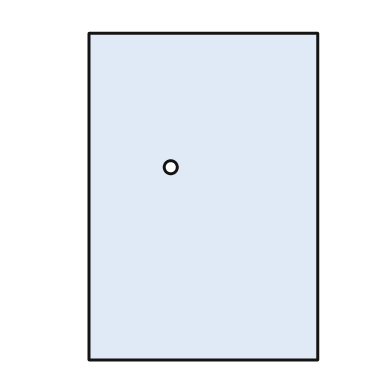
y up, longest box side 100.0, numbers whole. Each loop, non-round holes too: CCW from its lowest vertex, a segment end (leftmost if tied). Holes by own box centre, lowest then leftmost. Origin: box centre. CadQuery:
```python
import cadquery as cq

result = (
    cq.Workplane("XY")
    .moveTo(-35.0, -50.0)
    .lineTo(35.0, -50.0)
    .lineTo(35.0, 50.0)
    .lineTo(-35.0, 50.0)
    .close()
    .moveTo(-10.0, 9.0)
    .circle(2.0)
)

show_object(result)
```